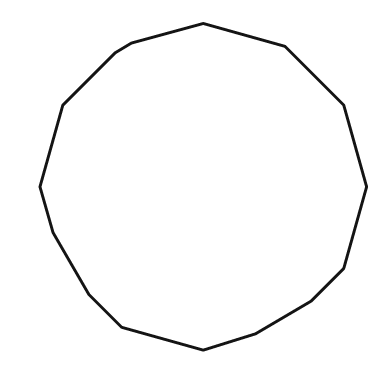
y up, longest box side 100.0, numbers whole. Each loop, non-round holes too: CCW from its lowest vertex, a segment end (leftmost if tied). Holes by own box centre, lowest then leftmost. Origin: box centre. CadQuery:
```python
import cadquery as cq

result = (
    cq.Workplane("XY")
    .moveTo(0.0, -50.0)
    .lineTo(16.0, -45.0)
    .lineTo(33.0, -35.0)
    .lineTo(43.0, -25.0)
    .lineTo(50.0, 0.0)
    .lineTo(43.0, 25.0)
    .lineTo(25.0, 43.0)
    .lineTo(0.0, 50.0)
    .lineTo(-22.0, 44.0)
    .lineTo(-27.0, 41.0)
    .lineTo(-43.0, 25.0)
    .lineTo(-50.0, 0.0)
    .lineTo(-46.0, -14.0)
    .lineTo(-35.0, -33.0)
    .lineTo(-25.0, -43.0)
    .close()
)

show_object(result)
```